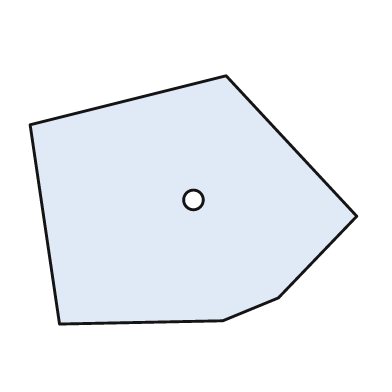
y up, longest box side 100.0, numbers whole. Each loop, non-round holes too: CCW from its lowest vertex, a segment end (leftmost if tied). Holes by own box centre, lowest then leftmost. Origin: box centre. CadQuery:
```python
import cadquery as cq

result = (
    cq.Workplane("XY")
    .moveTo(-41.0, -38.0)
    .lineTo(9.0, -37.0)
    .lineTo(26.0, -30.0)
    .lineTo(50.0, -5.0)
    .lineTo(10.0, 38.0)
    .lineTo(-50.0, 23.0)
    .close()
    .moveTo(0.0, 0.0)
    .circle(3.0)
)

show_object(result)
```